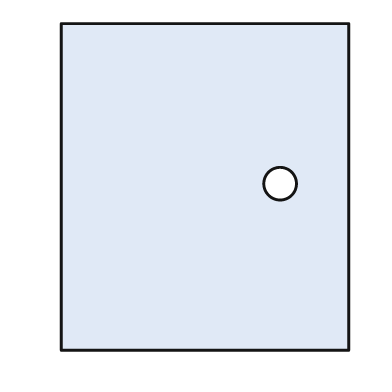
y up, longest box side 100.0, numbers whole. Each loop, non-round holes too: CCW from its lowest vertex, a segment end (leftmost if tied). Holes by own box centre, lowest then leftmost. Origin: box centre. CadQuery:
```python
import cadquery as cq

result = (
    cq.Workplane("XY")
    .moveTo(-44.0, -50.0)
    .lineTo(44.0, -50.0)
    .lineTo(44.0, 50.0)
    .lineTo(-44.0, 50.0)
    .close()
    .moveTo(23.0, 1.0)
    .circle(5.0)
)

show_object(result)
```